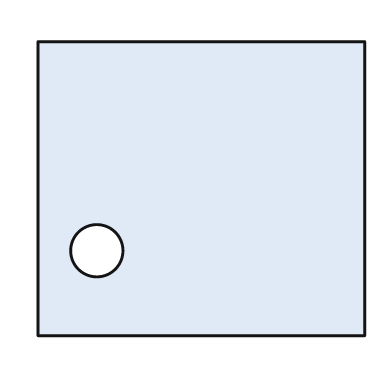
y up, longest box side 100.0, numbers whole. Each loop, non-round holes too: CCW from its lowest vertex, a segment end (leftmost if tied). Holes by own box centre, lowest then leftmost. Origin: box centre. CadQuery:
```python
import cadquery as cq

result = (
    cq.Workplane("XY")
    .moveTo(-50.0, -45.0)
    .lineTo(50.0, -45.0)
    .lineTo(50.0, 45.0)
    .lineTo(-50.0, 45.0)
    .close()
    .moveTo(-32.0, -19.0)
    .circle(8.0)
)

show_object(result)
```